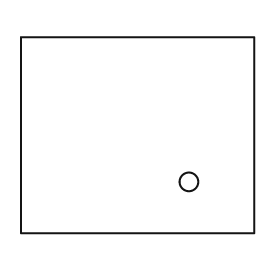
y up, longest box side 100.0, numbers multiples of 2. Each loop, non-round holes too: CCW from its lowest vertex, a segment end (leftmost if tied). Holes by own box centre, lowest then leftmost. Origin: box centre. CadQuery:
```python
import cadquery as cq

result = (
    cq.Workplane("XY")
    .moveTo(-50.0, -42.0)
    .lineTo(50.0, -42.0)
    .lineTo(50.0, 42.0)
    .lineTo(-50.0, 42.0)
    .close()
    .moveTo(22.0, -20.0)
    .circle(4.0)
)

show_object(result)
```